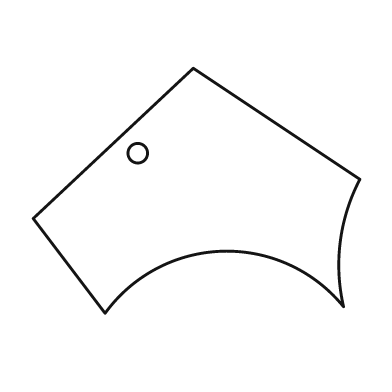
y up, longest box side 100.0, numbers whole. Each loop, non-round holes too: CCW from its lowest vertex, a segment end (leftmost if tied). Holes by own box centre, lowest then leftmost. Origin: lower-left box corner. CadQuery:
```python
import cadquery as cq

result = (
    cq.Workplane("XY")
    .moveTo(22.0, 0.0)
    .threePointArc((58.0, 19.0), (95.0, 2.0))
    .threePointArc((94.0, 22.0), (100.0, 41.0))
    .lineTo(49.0, 75.0)
    .lineTo(0.0, 29.0)
    .close()
    .moveTo(32.0, 49.0)
    .circle(3.0)
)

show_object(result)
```